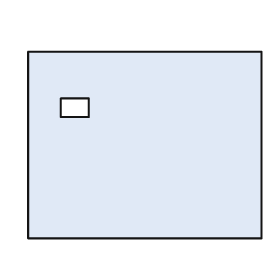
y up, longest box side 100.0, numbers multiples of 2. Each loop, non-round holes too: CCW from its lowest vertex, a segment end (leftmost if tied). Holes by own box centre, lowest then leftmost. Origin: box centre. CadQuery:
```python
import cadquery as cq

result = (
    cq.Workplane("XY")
    .moveTo(-50.0, -40.0)
    .lineTo(50.0, -40.0)
    .lineTo(50.0, 40.0)
    .lineTo(-50.0, 40.0)
    .close()
    .moveTo(-36.0, 12.0)
    .lineTo(-24.0, 12.0)
    .lineTo(-24.0, 20.0)
    .lineTo(-36.0, 20.0)
    .close()
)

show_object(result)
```